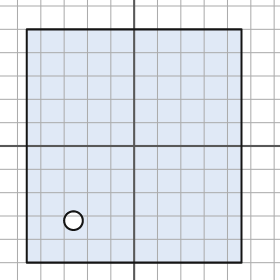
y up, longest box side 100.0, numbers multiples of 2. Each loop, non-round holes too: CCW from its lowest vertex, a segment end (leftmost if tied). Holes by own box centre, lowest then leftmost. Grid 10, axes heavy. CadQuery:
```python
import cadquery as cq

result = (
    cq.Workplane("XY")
    .moveTo(-46.0, -50.0)
    .lineTo(46.0, -50.0)
    .lineTo(46.0, 50.0)
    .lineTo(-46.0, 50.0)
    .close()
    .moveTo(-26.0, -32.0)
    .circle(4.0)
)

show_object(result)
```